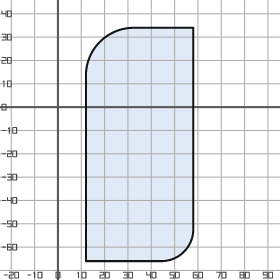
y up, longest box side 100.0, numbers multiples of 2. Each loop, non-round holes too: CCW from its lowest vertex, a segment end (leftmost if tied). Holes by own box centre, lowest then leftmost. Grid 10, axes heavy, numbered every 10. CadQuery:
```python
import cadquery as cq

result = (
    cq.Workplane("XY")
    .moveTo(12.0, -66.0)
    .lineTo(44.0, -66.0)
    .threePointArc((54.0, -62.0), (58.0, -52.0))
    .lineTo(58.0, 34.0)
    .lineTo(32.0, 34.0)
    .threePointArc((18.0, 28.0), (12.0, 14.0))
    .close()
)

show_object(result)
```